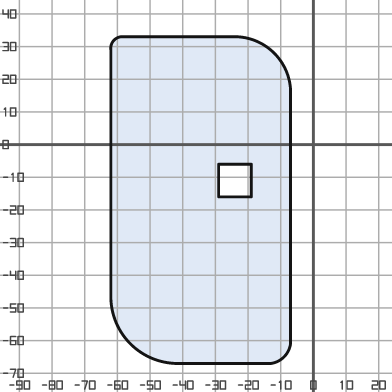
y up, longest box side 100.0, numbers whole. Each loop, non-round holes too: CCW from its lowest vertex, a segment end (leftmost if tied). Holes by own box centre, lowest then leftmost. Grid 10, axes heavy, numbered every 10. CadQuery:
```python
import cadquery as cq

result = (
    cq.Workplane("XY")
    .moveTo(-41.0, -67.0)
    .lineTo(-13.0, -67.0)
    .threePointArc((-9.0, -65.0), (-7.0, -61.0))
    .lineTo(-7.0, 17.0)
    .threePointArc((-12.0, 28.0), (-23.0, 33.0))
    .lineTo(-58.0, 33.0)
    .threePointArc((-61.0, 32.0), (-62.0, 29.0))
    .lineTo(-62.0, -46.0)
    .threePointArc((-56.0, -61.0), (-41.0, -67.0))
    .close()
    .moveTo(-29.0, -16.0)
    .lineTo(-19.0, -16.0)
    .lineTo(-19.0, -6.0)
    .lineTo(-29.0, -6.0)
    .close()
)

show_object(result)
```